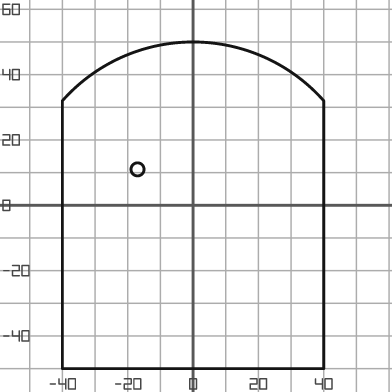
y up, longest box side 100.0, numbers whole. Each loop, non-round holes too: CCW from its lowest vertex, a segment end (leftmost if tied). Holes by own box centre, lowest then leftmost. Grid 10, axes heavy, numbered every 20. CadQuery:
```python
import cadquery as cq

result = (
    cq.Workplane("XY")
    .moveTo(-40.0, -50.0)
    .lineTo(40.0, -50.0)
    .lineTo(40.0, 32.0)
    .threePointArc((0.0, 50.0), (-40.0, 32.0))
    .close()
    .moveTo(-17.0, 11.0)
    .circle(2.0)
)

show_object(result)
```